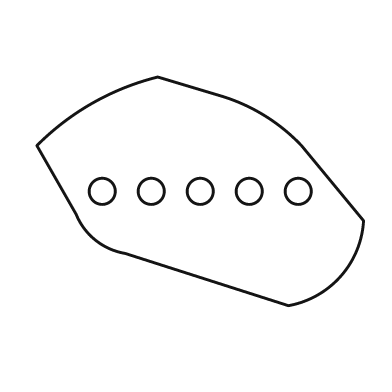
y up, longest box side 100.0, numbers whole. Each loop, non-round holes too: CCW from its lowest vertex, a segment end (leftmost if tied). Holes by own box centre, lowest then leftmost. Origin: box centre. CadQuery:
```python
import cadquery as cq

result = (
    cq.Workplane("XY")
    .moveTo(27.0, -35.0)
    .threePointArc((43.0, -26.0), (50.0, -9.0))
    .lineTo(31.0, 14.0)
    .threePointArc((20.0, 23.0), (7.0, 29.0))
    .lineTo(-13.0, 35.0)
    .threePointArc((-33.0, 27.0), (-50.0, 14.0))
    .lineTo(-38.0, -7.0)
    .threePointArc((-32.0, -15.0), (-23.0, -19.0))
    .close()
    .moveTo(-30.0, 0.0)
    .circle(4.0)
    .moveTo(-15.0, 0.0)
    .circle(4.0)
    .moveTo(0.0, 0.0)
    .circle(4.0)
    .moveTo(15.0, 0.0)
    .circle(4.0)
    .moveTo(30.0, 0.0)
    .circle(4.0)
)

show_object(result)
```